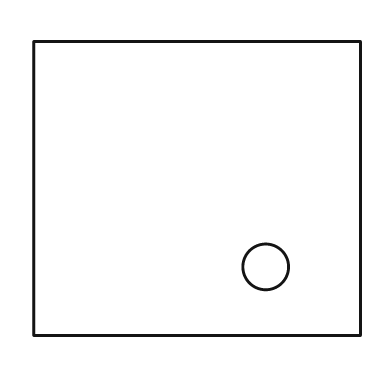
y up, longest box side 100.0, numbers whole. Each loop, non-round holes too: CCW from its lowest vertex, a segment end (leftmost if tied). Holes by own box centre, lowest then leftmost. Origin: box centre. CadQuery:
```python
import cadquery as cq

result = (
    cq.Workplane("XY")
    .moveTo(-50.0, -45.0)
    .lineTo(50.0, -45.0)
    .lineTo(50.0, 45.0)
    .lineTo(-50.0, 45.0)
    .close()
    .moveTo(21.0, -24.0)
    .circle(7.0)
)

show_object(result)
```